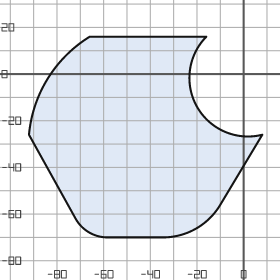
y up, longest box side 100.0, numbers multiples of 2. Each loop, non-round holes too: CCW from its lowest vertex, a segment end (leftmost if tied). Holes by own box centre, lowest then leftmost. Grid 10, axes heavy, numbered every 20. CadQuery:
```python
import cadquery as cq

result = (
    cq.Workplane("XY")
    .moveTo(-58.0, -70.0)
    .lineTo(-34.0, -70.0)
    .threePointArc((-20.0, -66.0), (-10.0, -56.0))
    .lineTo(8.0, -26.0)
    .threePointArc((-20.0, -14.0), (-16.0, 16.0))
    .lineTo(-66.0, 16.0)
    .threePointArc((-84.0, -2.0), (-92.0, -26.0))
    .lineTo(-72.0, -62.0)
    .threePointArc((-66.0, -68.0), (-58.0, -70.0))
    .close()
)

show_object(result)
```